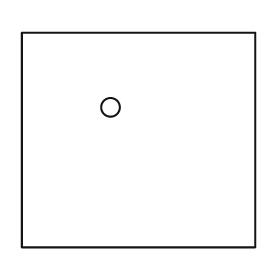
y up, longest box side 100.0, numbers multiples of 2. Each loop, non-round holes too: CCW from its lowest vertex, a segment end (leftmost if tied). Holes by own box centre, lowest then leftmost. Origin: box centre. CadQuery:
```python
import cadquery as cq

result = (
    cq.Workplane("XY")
    .moveTo(-50.0, -46.0)
    .lineTo(50.0, -46.0)
    .lineTo(50.0, 46.0)
    .lineTo(-50.0, 46.0)
    .close()
    .moveTo(-12.0, 14.0)
    .circle(4.0)
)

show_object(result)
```